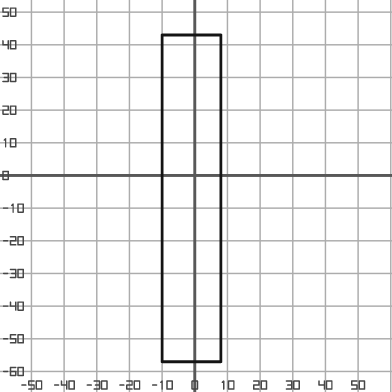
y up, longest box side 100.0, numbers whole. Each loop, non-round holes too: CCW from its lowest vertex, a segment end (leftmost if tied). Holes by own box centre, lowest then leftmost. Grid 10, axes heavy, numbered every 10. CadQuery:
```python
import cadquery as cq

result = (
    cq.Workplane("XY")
    .moveTo(-10.0, -57.0)
    .lineTo(8.0, -57.0)
    .lineTo(8.0, 43.0)
    .lineTo(-10.0, 43.0)
    .close()
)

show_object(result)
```